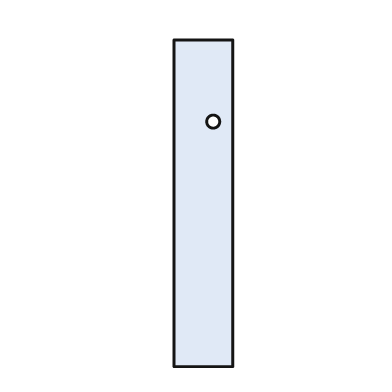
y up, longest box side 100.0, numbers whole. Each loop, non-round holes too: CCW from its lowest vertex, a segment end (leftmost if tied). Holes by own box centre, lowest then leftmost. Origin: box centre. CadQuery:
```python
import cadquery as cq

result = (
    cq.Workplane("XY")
    .moveTo(-9.0, -50.0)
    .lineTo(9.0, -50.0)
    .lineTo(9.0, 50.0)
    .lineTo(-9.0, 50.0)
    .close()
    .moveTo(3.0, 25.0)
    .circle(2.0)
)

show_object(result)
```